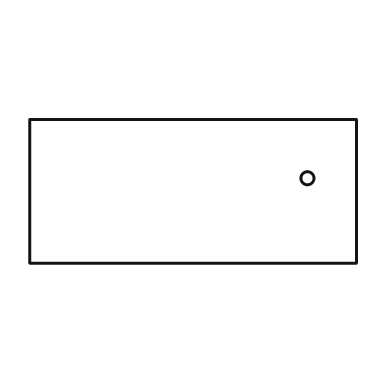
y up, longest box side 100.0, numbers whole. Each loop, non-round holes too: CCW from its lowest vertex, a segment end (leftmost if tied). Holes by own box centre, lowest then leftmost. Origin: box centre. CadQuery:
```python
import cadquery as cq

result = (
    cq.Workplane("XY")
    .moveTo(-50.0, -22.0)
    .lineTo(50.0, -22.0)
    .lineTo(50.0, 22.0)
    .lineTo(-50.0, 22.0)
    .close()
    .moveTo(35.0, 4.0)
    .circle(2.0)
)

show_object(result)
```